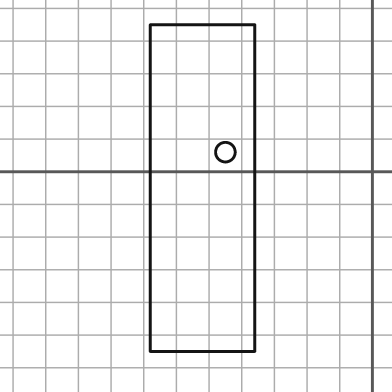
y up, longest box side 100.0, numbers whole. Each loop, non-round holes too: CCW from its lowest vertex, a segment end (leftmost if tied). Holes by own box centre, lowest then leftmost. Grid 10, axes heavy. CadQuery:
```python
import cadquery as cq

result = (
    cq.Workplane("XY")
    .moveTo(-68.0, -55.0)
    .lineTo(-36.0, -55.0)
    .lineTo(-36.0, 45.0)
    .lineTo(-68.0, 45.0)
    .close()
    .moveTo(-45.0, 6.0)
    .circle(3.0)
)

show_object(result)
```